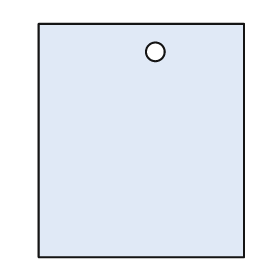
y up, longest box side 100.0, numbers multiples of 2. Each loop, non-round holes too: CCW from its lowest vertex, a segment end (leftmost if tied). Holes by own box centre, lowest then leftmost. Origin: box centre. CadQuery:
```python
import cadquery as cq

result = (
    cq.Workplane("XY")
    .moveTo(-44.0, -50.0)
    .lineTo(44.0, -50.0)
    .lineTo(44.0, 50.0)
    .lineTo(-44.0, 50.0)
    .close()
    .moveTo(6.0, 38.0)
    .circle(4.0)
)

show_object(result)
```